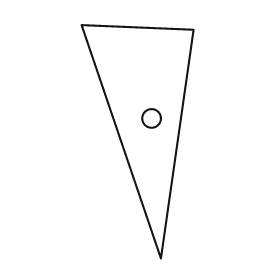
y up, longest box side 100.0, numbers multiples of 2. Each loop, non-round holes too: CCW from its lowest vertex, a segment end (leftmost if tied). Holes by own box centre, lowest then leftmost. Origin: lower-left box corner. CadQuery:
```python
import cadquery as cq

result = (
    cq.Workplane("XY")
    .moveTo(34.0, 0.0)
    .lineTo(48.0, 98.0)
    .lineTo(0.0, 100.0)
    .close()
    .moveTo(30.0, 60.0)
    .circle(4.0)
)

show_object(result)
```